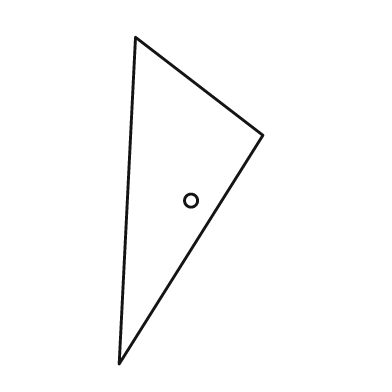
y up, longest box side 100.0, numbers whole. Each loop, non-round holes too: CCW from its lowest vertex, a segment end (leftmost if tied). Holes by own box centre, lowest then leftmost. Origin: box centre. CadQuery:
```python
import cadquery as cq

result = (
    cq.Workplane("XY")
    .moveTo(-22.0, -50.0)
    .lineTo(22.0, 20.0)
    .lineTo(-17.0, 50.0)
    .close()
    .moveTo(0.0, 0.0)
    .circle(2.0)
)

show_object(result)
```